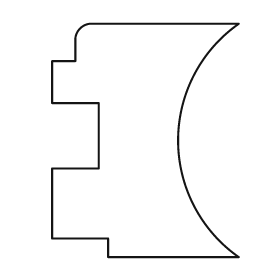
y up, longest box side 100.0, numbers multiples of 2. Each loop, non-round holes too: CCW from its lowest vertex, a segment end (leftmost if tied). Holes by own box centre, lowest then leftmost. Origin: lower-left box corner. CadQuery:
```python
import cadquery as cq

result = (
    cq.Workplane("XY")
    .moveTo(24.0, 0.0)
    .lineTo(80.0, 0.0)
    .threePointArc((54.0, 50.0), (80.0, 100.0))
    .lineTo(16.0, 100.0)
    .threePointArc((12.0, 98.0), (10.0, 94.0))
    .lineTo(10.0, 84.0)
    .lineTo(0.0, 84.0)
    .lineTo(0.0, 66.0)
    .lineTo(20.0, 66.0)
    .lineTo(20.0, 38.0)
    .lineTo(0.0, 38.0)
    .lineTo(0.0, 8.0)
    .lineTo(24.0, 8.0)
    .close()
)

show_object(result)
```